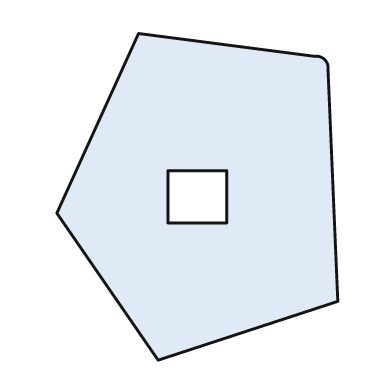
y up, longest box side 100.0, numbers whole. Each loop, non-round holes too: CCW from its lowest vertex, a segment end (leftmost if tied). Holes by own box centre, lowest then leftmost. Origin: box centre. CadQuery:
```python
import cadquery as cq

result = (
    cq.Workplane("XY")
    .moveTo(-12.0, -50.0)
    .lineTo(43.0, -32.0)
    .lineTo(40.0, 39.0)
    .threePointArc((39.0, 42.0), (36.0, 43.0))
    .lineTo(-18.0, 50.0)
    .lineTo(-43.0, -5.0)
    .close()
    .moveTo(-9.0, -8.0)
    .lineTo(9.0, -8.0)
    .lineTo(9.0, 8.0)
    .lineTo(-9.0, 8.0)
    .close()
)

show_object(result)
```